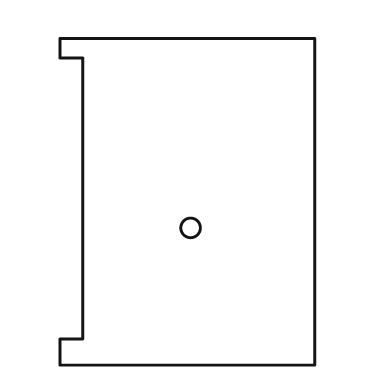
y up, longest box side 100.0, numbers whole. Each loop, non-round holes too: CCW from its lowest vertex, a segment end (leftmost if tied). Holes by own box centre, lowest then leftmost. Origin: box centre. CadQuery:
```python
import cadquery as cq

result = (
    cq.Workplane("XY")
    .moveTo(-39.0, -50.0)
    .lineTo(39.0, -50.0)
    .lineTo(39.0, 50.0)
    .lineTo(-39.0, 50.0)
    .lineTo(-39.0, 44.0)
    .lineTo(-32.0, 44.0)
    .lineTo(-32.0, -42.0)
    .lineTo(-39.0, -42.0)
    .close()
    .moveTo(1.0, -8.0)
    .circle(3.0)
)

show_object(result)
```